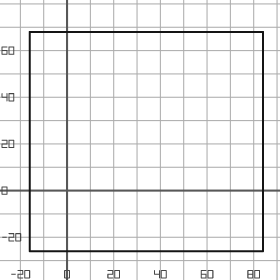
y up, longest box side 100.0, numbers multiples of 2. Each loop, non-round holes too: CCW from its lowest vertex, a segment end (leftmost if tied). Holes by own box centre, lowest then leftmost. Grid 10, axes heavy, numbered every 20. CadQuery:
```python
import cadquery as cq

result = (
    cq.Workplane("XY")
    .moveTo(-16.0, -26.0)
    .lineTo(84.0, -26.0)
    .lineTo(84.0, 68.0)
    .lineTo(-16.0, 68.0)
    .close()
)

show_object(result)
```